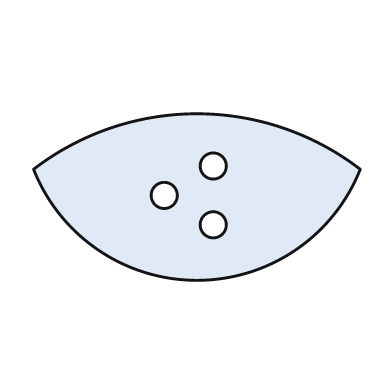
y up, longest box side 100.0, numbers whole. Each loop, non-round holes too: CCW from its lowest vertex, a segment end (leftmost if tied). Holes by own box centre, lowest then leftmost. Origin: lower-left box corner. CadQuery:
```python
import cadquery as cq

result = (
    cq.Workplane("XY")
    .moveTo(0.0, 34.0)
    .threePointArc((50.0, 0.0), (100.0, 34.0))
    .threePointArc((50.0, 51.0), (0.0, 34.0))
    .close()
    .moveTo(55.0, 17.0)
    .circle(4.0)
    .moveTo(40.0, 26.0)
    .circle(4.0)
    .moveTo(55.0, 35.0)
    .circle(4.0)
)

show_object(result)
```